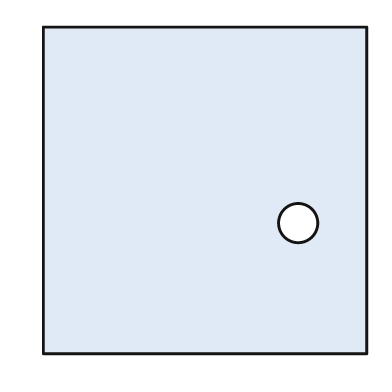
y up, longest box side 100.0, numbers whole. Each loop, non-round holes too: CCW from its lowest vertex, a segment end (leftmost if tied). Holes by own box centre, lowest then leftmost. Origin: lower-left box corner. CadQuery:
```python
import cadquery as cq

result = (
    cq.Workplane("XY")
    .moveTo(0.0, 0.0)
    .lineTo(99.0, 0.0)
    .lineTo(99.0, 100.0)
    .lineTo(0.0, 100.0)
    .close()
    .moveTo(78.0, 40.0)
    .circle(6.0)
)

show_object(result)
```